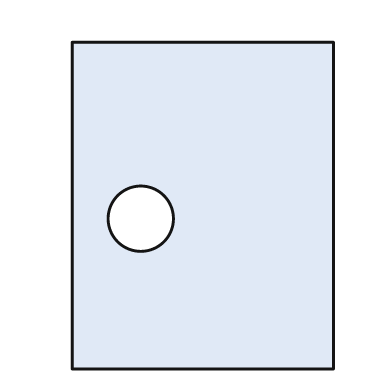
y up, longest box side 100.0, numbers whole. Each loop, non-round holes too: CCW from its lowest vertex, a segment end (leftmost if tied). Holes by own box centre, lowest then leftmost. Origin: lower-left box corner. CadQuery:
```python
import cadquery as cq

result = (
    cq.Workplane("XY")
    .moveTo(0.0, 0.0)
    .lineTo(80.0, 0.0)
    .lineTo(80.0, 100.0)
    .lineTo(0.0, 100.0)
    .close()
    .moveTo(21.0, 46.0)
    .circle(10.0)
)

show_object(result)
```